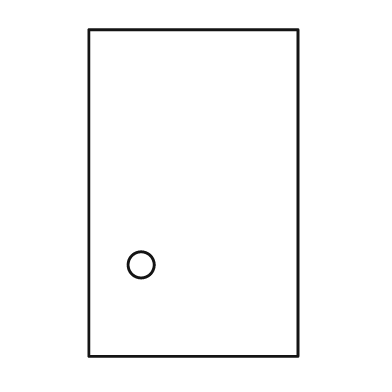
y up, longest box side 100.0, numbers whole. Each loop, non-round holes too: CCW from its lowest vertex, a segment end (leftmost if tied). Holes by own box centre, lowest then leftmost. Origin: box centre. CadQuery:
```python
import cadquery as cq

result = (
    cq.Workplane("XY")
    .moveTo(-32.0, -50.0)
    .lineTo(32.0, -50.0)
    .lineTo(32.0, 50.0)
    .lineTo(-32.0, 50.0)
    .close()
    .moveTo(-16.0, -22.0)
    .circle(4.0)
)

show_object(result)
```